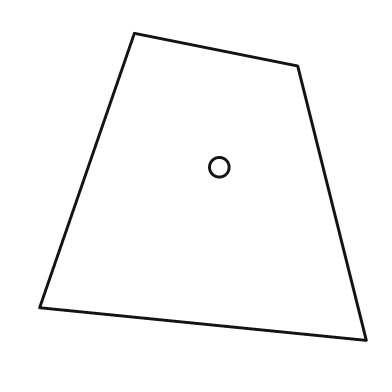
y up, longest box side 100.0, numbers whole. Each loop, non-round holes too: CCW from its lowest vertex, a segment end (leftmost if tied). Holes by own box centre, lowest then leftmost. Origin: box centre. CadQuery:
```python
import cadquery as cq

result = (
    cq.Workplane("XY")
    .moveTo(50.0, -47.0)
    .lineTo(29.0, 37.0)
    .lineTo(-21.0, 47.0)
    .lineTo(-50.0, -37.0)
    .close()
    .moveTo(5.0, 6.0)
    .circle(3.0)
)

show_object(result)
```